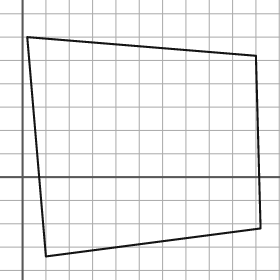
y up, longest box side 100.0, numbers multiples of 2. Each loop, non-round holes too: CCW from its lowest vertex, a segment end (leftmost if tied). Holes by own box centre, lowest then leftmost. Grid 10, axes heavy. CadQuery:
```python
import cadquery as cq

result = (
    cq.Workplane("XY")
    .moveTo(10.0, -34.0)
    .lineTo(102.0, -22.0)
    .lineTo(100.0, 52.0)
    .lineTo(2.0, 60.0)
    .close()
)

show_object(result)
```